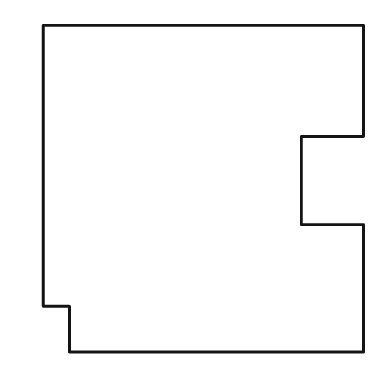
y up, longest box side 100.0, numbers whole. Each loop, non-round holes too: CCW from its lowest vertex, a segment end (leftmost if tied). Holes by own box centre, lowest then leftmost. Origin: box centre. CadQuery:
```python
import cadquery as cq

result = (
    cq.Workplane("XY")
    .moveTo(-41.0, -50.0)
    .lineTo(49.0, -50.0)
    .lineTo(49.0, -11.0)
    .lineTo(30.0, -11.0)
    .lineTo(30.0, 16.0)
    .lineTo(49.0, 16.0)
    .lineTo(49.0, 50.0)
    .lineTo(-49.0, 50.0)
    .lineTo(-49.0, -36.0)
    .lineTo(-41.0, -36.0)
    .close()
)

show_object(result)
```